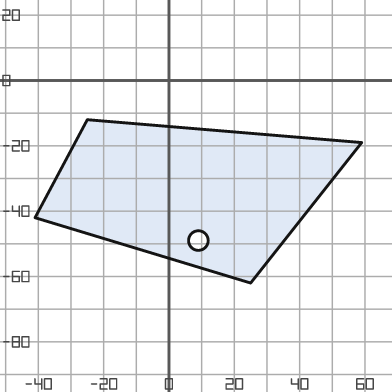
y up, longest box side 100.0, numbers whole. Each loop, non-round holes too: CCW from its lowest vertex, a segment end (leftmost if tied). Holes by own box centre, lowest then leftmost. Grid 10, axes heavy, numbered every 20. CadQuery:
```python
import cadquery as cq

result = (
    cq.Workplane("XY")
    .moveTo(25.0, -62.0)
    .lineTo(59.0, -19.0)
    .lineTo(-25.0, -12.0)
    .lineTo(-41.0, -42.0)
    .close()
    .moveTo(9.0, -49.0)
    .circle(3.0)
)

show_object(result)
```